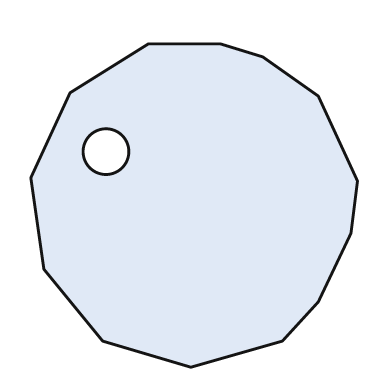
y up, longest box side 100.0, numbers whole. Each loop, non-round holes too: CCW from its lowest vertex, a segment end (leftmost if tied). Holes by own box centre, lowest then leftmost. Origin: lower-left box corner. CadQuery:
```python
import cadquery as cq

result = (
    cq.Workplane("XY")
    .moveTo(49.0, 0.0)
    .lineTo(77.0, 8.0)
    .lineTo(88.0, 20.0)
    .lineTo(98.0, 41.0)
    .lineTo(100.0, 57.0)
    .lineTo(88.0, 83.0)
    .lineTo(71.0, 95.0)
    .lineTo(58.0, 99.0)
    .lineTo(36.0, 99.0)
    .lineTo(12.0, 84.0)
    .lineTo(0.0, 58.0)
    .lineTo(4.0, 30.0)
    .lineTo(22.0, 8.0)
    .close()
    .moveTo(23.0, 66.0)
    .circle(7.0)
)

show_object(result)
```